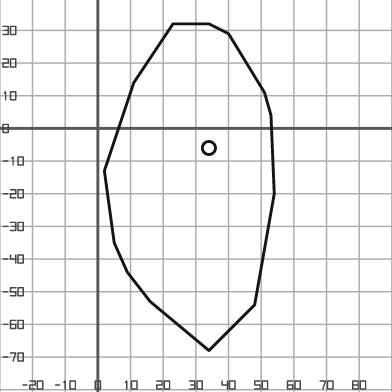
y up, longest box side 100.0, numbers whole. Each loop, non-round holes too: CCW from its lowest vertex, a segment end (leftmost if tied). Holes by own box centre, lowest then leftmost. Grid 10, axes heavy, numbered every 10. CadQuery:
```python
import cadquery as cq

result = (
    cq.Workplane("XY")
    .moveTo(34.0, -68.0)
    .lineTo(48.0, -54.0)
    .lineTo(54.0, -20.0)
    .lineTo(53.0, 4.0)
    .lineTo(51.0, 11.0)
    .lineTo(40.0, 29.0)
    .lineTo(34.0, 32.0)
    .lineTo(23.0, 32.0)
    .lineTo(11.0, 14.0)
    .lineTo(2.0, -13.0)
    .lineTo(5.0, -35.0)
    .lineTo(9.0, -44.0)
    .lineTo(16.0, -53.0)
    .close()
    .moveTo(34.0, -6.0)
    .circle(2.0)
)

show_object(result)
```